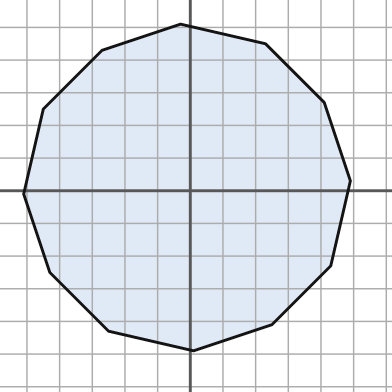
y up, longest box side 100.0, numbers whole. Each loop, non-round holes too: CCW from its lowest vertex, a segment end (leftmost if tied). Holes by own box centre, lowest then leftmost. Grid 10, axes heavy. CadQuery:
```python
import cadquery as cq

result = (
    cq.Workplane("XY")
    .moveTo(1.0, -49.0)
    .lineTo(25.0, -41.0)
    .lineTo(43.0, -23.0)
    .lineTo(49.0, 3.0)
    .lineTo(41.0, 27.0)
    .lineTo(23.0, 45.0)
    .lineTo(-3.0, 51.0)
    .lineTo(-27.0, 43.0)
    .lineTo(-45.0, 25.0)
    .lineTo(-51.0, -1.0)
    .lineTo(-43.0, -25.0)
    .lineTo(-25.0, -43.0)
    .close()
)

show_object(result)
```